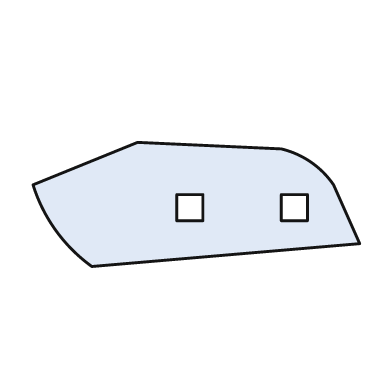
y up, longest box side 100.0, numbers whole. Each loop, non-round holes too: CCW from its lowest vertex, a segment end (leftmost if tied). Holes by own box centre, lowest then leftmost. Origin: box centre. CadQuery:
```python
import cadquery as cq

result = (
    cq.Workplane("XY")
    .moveTo(-32.0, -19.0)
    .lineTo(50.0, -12.0)
    .lineTo(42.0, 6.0)
    .threePointArc((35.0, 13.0), (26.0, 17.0))
    .lineTo(-18.0, 19.0)
    .lineTo(-50.0, 6.0)
    .threePointArc((-43.0, -8.0), (-32.0, -19.0))
    .close()
    .moveTo(-6.0, -5.0)
    .lineTo(2.0, -5.0)
    .lineTo(2.0, 3.0)
    .lineTo(-6.0, 3.0)
    .close()
    .moveTo(26.0, -5.0)
    .lineTo(34.0, -5.0)
    .lineTo(34.0, 3.0)
    .lineTo(26.0, 3.0)
    .close()
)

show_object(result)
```